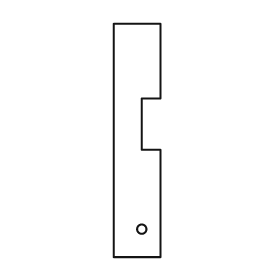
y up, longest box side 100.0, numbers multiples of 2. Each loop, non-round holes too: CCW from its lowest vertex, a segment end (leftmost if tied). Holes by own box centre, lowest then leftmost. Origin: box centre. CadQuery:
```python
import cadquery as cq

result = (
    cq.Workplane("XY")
    .moveTo(-10.0, -50.0)
    .lineTo(10.0, -50.0)
    .lineTo(10.0, -4.0)
    .lineTo(2.0, -4.0)
    .lineTo(2.0, 18.0)
    .lineTo(10.0, 18.0)
    .lineTo(10.0, 50.0)
    .lineTo(-10.0, 50.0)
    .close()
    .moveTo(2.0, -38.0)
    .circle(2.0)
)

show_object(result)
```